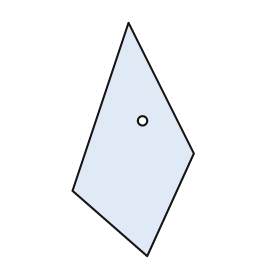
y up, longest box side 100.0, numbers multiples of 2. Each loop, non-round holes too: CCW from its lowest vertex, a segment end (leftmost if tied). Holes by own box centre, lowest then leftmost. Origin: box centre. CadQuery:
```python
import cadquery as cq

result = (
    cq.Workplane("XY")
    .moveTo(6.0, -50.0)
    .lineTo(26.0, -6.0)
    .lineTo(-2.0, 50.0)
    .lineTo(-26.0, -22.0)
    .close()
    .moveTo(4.0, 8.0)
    .circle(2.0)
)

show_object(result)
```